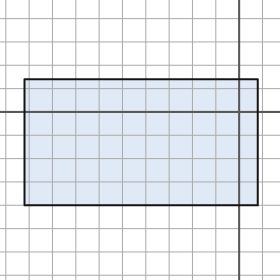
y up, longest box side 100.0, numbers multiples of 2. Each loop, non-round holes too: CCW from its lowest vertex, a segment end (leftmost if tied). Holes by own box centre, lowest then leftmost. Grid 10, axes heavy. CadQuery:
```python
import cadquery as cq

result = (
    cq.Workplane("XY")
    .moveTo(-92.0, -40.0)
    .lineTo(8.0, -40.0)
    .lineTo(8.0, 14.0)
    .lineTo(-92.0, 14.0)
    .close()
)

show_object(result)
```